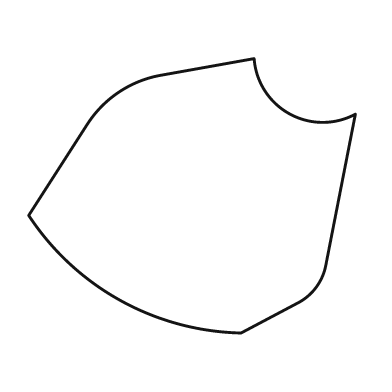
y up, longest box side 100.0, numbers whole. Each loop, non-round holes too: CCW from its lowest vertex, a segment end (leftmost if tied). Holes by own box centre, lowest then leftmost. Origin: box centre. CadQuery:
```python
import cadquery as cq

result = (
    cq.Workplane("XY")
    .moveTo(15.0, -42.0)
    .lineTo(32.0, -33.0)
    .threePointArc((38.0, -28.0), (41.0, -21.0))
    .lineTo(50.0, 25.0)
    .threePointArc((30.0, 25.0), (19.0, 42.0))
    .lineTo(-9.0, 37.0)
    .threePointArc((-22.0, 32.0), (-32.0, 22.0))
    .lineTo(-50.0, -6.0)
    .threePointArc((-22.0, -32.0), (15.0, -42.0))
    .close()
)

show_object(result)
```